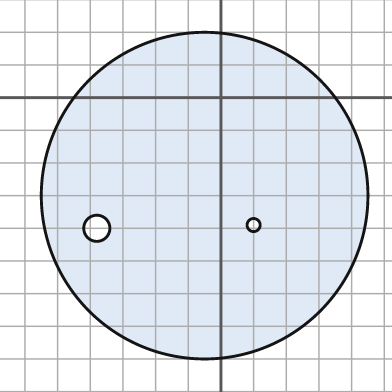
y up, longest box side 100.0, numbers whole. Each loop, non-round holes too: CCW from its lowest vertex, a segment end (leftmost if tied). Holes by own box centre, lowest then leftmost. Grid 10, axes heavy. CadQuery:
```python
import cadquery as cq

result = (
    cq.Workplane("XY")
    .moveTo(-5.0, -30.0)
    .circle(50.0)
    .moveTo(-38.0, -40.0)
    .circle(4.0)
    .moveTo(10.0, -39.0)
    .circle(2.0)
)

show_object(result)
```